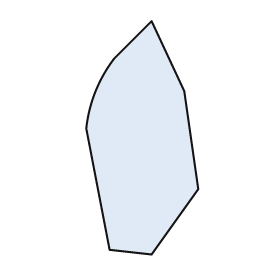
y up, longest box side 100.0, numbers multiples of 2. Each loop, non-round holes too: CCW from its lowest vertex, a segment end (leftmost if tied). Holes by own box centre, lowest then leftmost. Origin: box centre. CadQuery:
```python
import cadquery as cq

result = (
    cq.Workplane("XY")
    .moveTo(4.0, -50.0)
    .lineTo(24.0, -22.0)
    .lineTo(18.0, 20.0)
    .lineTo(4.0, 50.0)
    .lineTo(-12.0, 34.0)
    .threePointArc((-20.0, 20.0), (-24.0, 4.0))
    .lineTo(-14.0, -48.0)
    .close()
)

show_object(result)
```